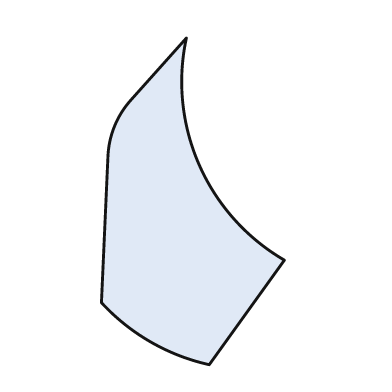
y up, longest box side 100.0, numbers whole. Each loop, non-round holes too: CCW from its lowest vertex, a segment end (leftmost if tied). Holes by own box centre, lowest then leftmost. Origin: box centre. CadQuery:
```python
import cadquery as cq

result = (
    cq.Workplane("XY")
    .moveTo(5.0, -50.0)
    .lineTo(28.0, -18.0)
    .threePointArc((2.0, 11.0), (-2.0, 50.0))
    .lineTo(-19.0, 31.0)
    .threePointArc((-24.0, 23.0), (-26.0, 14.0))
    .lineTo(-28.0, -31.0)
    .threePointArc((-13.0, -43.0), (5.0, -50.0))
    .close()
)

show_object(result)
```